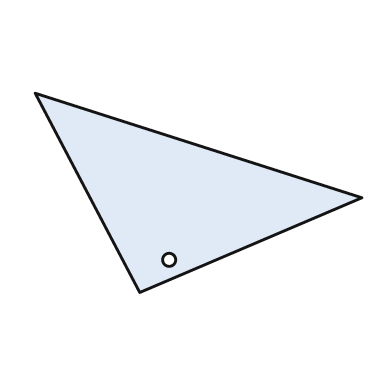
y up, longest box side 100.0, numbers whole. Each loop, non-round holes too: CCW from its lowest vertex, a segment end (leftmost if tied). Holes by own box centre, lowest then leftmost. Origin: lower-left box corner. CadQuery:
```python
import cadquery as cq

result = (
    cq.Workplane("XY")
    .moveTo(32.0, 0.0)
    .lineTo(100.0, 29.0)
    .lineTo(0.0, 61.0)
    .close()
    .moveTo(41.0, 10.0)
    .circle(2.0)
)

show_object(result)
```